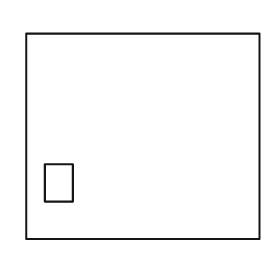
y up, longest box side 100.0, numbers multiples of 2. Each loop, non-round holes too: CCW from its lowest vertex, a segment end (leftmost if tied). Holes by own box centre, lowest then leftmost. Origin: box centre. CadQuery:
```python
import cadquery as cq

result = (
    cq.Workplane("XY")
    .moveTo(-50.0, -44.0)
    .lineTo(50.0, -44.0)
    .lineTo(50.0, 44.0)
    .lineTo(-50.0, 44.0)
    .close()
    .moveTo(-42.0, -28.0)
    .lineTo(-30.0, -28.0)
    .lineTo(-30.0, -12.0)
    .lineTo(-42.0, -12.0)
    .close()
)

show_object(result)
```